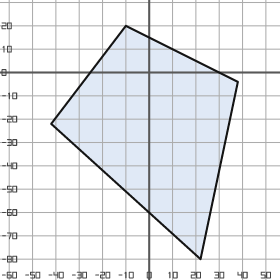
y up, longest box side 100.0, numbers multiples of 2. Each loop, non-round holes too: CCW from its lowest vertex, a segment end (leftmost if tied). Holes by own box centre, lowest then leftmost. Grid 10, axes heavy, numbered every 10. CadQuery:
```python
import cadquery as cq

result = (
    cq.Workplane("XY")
    .moveTo(22.0, -80.0)
    .lineTo(38.0, -4.0)
    .lineTo(-10.0, 20.0)
    .lineTo(-42.0, -22.0)
    .close()
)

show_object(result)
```